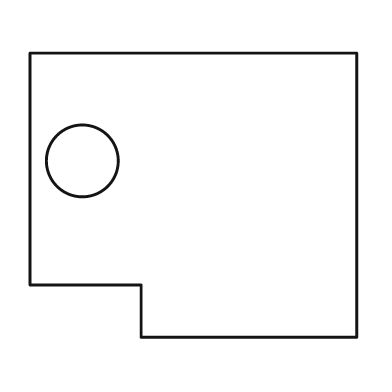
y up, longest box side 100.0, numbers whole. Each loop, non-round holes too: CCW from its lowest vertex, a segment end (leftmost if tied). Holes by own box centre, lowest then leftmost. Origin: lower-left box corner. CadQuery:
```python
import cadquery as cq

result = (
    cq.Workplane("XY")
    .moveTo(34.0, 0.0)
    .lineTo(100.0, 0.0)
    .lineTo(100.0, 87.0)
    .lineTo(0.0, 87.0)
    .lineTo(0.0, 16.0)
    .lineTo(34.0, 16.0)
    .close()
    .moveTo(16.0, 54.0)
    .circle(11.0)
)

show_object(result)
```